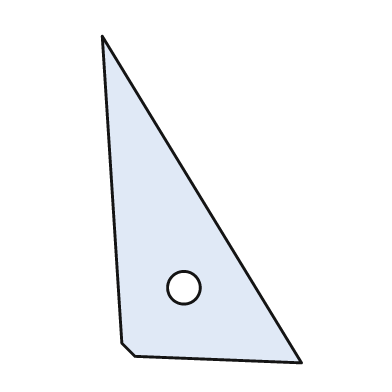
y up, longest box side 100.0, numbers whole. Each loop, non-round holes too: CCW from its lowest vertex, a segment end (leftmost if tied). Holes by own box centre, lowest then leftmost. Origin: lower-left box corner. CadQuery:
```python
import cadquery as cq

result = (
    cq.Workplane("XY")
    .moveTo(61.0, 0.0)
    .lineTo(0.0, 100.0)
    .lineTo(6.0, 6.0)
    .lineTo(10.0, 2.0)
    .close()
    .moveTo(25.0, 23.0)
    .circle(5.0)
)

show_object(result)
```